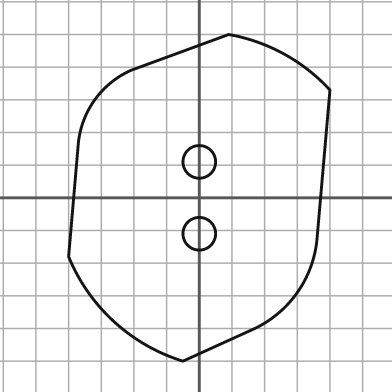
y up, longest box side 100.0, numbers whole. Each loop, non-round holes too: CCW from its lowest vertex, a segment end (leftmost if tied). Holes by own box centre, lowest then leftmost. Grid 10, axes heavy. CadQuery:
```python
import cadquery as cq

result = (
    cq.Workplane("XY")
    .moveTo(-5.0, -50.0)
    .lineTo(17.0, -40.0)
    .threePointArc((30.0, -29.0), (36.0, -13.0))
    .lineTo(40.0, 33.0)
    .threePointArc((26.0, 44.0), (9.0, 50.0))
    .lineTo(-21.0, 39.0)
    .threePointArc((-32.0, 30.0), (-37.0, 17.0))
    .lineTo(-40.0, -18.0)
    .threePointArc((-26.0, -38.0), (-5.0, -50.0))
    .close()
    .moveTo(0.0, -11.0)
    .circle(5.0)
    .moveTo(0.0, 11.0)
    .circle(5.0)
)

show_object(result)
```